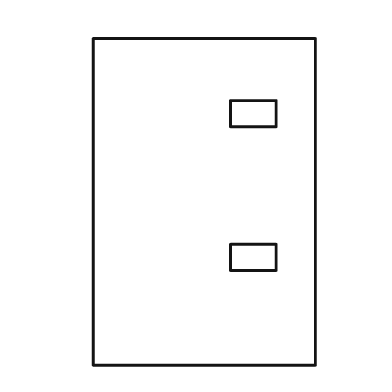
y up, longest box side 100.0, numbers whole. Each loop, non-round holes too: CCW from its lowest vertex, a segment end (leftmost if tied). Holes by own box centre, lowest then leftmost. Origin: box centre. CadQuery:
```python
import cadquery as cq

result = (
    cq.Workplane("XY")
    .moveTo(-34.0, -50.0)
    .lineTo(34.0, -50.0)
    .lineTo(34.0, 50.0)
    .lineTo(-34.0, 50.0)
    .close()
    .moveTo(8.0, -21.0)
    .lineTo(22.0, -21.0)
    .lineTo(22.0, -13.0)
    .lineTo(8.0, -13.0)
    .close()
    .moveTo(8.0, 23.0)
    .lineTo(22.0, 23.0)
    .lineTo(22.0, 31.0)
    .lineTo(8.0, 31.0)
    .close()
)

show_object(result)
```